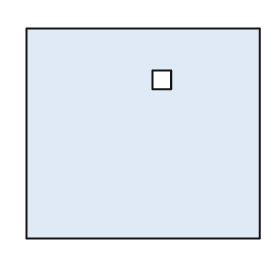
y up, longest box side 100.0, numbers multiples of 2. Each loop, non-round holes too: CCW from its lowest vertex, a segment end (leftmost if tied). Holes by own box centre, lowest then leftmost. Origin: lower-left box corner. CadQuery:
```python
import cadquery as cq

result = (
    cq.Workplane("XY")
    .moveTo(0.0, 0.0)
    .lineTo(100.0, 0.0)
    .lineTo(100.0, 90.0)
    .lineTo(0.0, 90.0)
    .close()
    .moveTo(54.0, 64.0)
    .lineTo(62.0, 64.0)
    .lineTo(62.0, 72.0)
    .lineTo(54.0, 72.0)
    .close()
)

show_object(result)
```